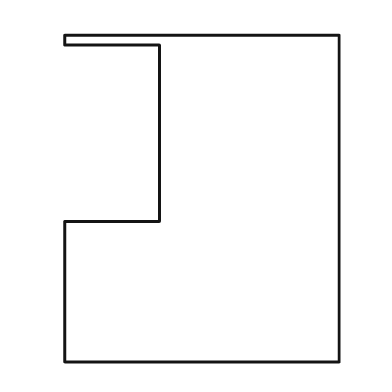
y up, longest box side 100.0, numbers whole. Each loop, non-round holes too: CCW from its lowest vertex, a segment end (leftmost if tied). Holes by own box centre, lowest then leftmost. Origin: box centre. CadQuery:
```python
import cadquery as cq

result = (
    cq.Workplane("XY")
    .moveTo(-42.0, -50.0)
    .lineTo(42.0, -50.0)
    .lineTo(42.0, 50.0)
    .lineTo(-42.0, 50.0)
    .lineTo(-42.0, 47.0)
    .lineTo(-13.0, 47.0)
    .lineTo(-13.0, -7.0)
    .lineTo(-42.0, -7.0)
    .close()
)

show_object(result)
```